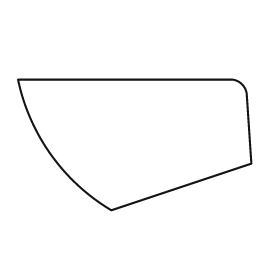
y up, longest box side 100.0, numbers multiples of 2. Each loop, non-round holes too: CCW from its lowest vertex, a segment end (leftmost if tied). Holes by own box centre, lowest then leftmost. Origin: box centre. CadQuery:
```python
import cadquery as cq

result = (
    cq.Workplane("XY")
    .moveTo(-10.0, -28.0)
    .lineTo(50.0, -8.0)
    .lineTo(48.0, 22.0)
    .threePointArc((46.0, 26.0), (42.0, 28.0))
    .lineTo(-50.0, 28.0)
    .threePointArc((-36.0, -4.0), (-10.0, -28.0))
    .close()
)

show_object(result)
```